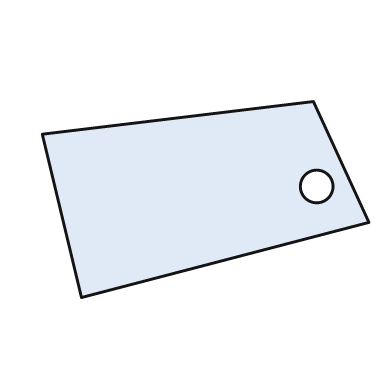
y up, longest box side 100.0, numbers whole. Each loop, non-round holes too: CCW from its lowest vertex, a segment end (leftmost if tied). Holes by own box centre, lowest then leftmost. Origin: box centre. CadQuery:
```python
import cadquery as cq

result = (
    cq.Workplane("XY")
    .moveTo(-38.0, -30.0)
    .lineTo(50.0, -7.0)
    .lineTo(33.0, 30.0)
    .lineTo(-50.0, 20.0)
    .close()
    .moveTo(34.0, 4.0)
    .circle(5.0)
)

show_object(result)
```